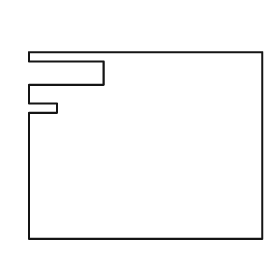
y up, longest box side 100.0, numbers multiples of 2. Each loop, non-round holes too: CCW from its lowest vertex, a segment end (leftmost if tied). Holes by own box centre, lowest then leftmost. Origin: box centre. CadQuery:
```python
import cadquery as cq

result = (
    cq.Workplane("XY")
    .moveTo(-50.0, -40.0)
    .lineTo(50.0, -40.0)
    .lineTo(50.0, 40.0)
    .lineTo(-50.0, 40.0)
    .lineTo(-50.0, 36.0)
    .lineTo(-18.0, 36.0)
    .lineTo(-18.0, 26.0)
    .lineTo(-50.0, 26.0)
    .lineTo(-50.0, 18.0)
    .lineTo(-38.0, 18.0)
    .lineTo(-38.0, 14.0)
    .lineTo(-50.0, 14.0)
    .close()
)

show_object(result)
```